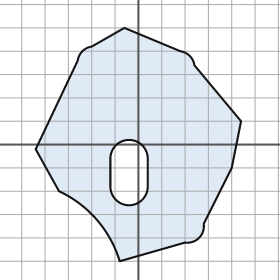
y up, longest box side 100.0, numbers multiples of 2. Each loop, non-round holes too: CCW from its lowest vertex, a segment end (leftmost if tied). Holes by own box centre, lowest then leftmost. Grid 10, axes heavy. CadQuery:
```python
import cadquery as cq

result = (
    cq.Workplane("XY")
    .moveTo(-8.0, -50.0)
    .lineTo(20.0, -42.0)
    .threePointArc((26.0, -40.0), (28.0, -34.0))
    .lineTo(40.0, -10.0)
    .lineTo(44.0, 10.0)
    .lineTo(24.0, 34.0)
    .threePointArc((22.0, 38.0), (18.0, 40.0))
    .lineTo(-6.0, 50.0)
    .lineTo(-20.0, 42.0)
    .threePointArc((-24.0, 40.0), (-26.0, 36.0))
    .lineTo(-44.0, -2.0)
    .lineTo(-34.0, -20.0)
    .threePointArc((-18.0, -32.0), (-8.0, -50.0))
    .close()
    .moveTo(-12.0, -18.0)
    .threePointArc((-4.0, -26.0), (4.0, -18.0))
    .lineTo(4.0, -6.0)
    .threePointArc((-4.0, 2.0), (-12.0, -6.0))
    .close()
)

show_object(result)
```